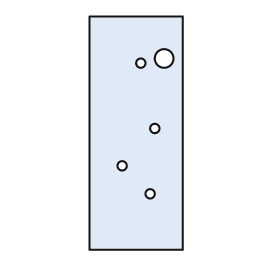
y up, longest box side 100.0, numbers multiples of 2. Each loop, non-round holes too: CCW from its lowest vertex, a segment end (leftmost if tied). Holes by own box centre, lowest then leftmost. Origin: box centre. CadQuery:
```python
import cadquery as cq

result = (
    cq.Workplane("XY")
    .moveTo(-20.0, -50.0)
    .lineTo(20.0, -50.0)
    .lineTo(20.0, 50.0)
    .lineTo(-20.0, 50.0)
    .close()
    .moveTo(6.0, -26.0)
    .circle(2.0)
    .moveTo(-6.0, -14.0)
    .circle(2.0)
    .moveTo(8.0, 2.0)
    .circle(2.0)
    .moveTo(2.0, 30.0)
    .circle(2.0)
    .moveTo(12.0, 32.0)
    .circle(4.0)
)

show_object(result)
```